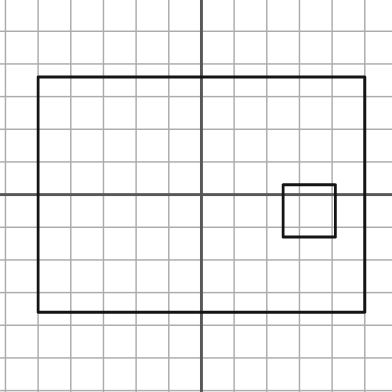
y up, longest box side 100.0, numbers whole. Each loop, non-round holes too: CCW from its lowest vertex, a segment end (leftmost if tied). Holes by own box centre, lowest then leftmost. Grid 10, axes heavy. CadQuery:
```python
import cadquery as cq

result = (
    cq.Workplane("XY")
    .moveTo(-50.0, -36.0)
    .lineTo(50.0, -36.0)
    .lineTo(50.0, 36.0)
    .lineTo(-50.0, 36.0)
    .close()
    .moveTo(25.0, -13.0)
    .lineTo(41.0, -13.0)
    .lineTo(41.0, 3.0)
    .lineTo(25.0, 3.0)
    .close()
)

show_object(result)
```